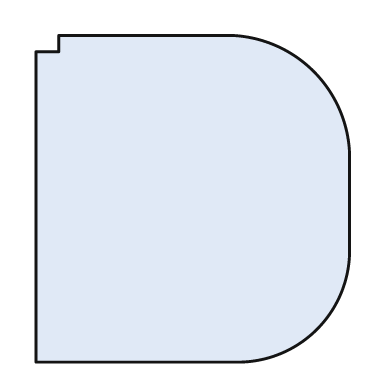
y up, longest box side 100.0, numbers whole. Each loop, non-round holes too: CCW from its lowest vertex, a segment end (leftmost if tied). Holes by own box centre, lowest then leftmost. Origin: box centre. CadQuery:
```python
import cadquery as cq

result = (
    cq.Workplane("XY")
    .moveTo(-48.0, -50.0)
    .lineTo(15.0, -50.0)
    .threePointArc((38.0, -40.0), (48.0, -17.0))
    .lineTo(48.0, 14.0)
    .threePointArc((37.0, 39.0), (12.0, 50.0))
    .lineTo(-41.0, 50.0)
    .lineTo(-41.0, 45.0)
    .lineTo(-48.0, 45.0)
    .close()
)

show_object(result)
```